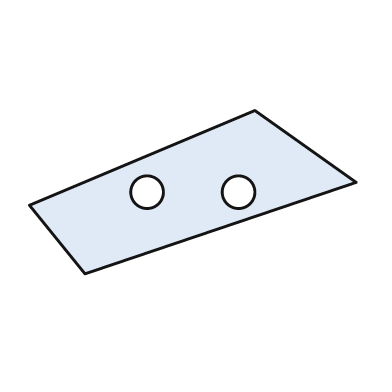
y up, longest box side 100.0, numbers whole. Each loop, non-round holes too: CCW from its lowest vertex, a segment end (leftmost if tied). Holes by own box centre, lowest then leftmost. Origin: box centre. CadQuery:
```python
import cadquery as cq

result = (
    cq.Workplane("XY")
    .moveTo(-33.0, -25.0)
    .lineTo(50.0, 3.0)
    .lineTo(19.0, 25.0)
    .lineTo(-50.0, -4.0)
    .close()
    .moveTo(-14.0, 0.0)
    .circle(5.0)
    .moveTo(14.0, 0.0)
    .circle(5.0)
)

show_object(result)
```